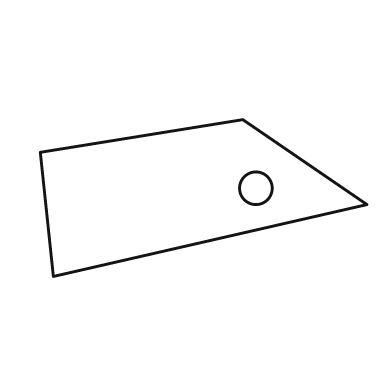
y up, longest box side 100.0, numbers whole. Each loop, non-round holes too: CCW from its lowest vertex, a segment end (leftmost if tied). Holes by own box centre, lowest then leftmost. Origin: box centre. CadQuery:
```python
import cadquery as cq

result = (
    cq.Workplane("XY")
    .moveTo(-46.0, -24.0)
    .lineTo(50.0, -2.0)
    .lineTo(12.0, 24.0)
    .lineTo(-50.0, 14.0)
    .close()
    .moveTo(16.0, 3.0)
    .circle(5.0)
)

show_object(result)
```